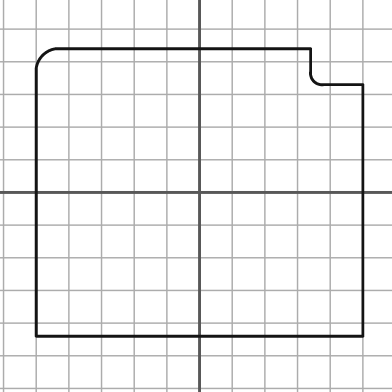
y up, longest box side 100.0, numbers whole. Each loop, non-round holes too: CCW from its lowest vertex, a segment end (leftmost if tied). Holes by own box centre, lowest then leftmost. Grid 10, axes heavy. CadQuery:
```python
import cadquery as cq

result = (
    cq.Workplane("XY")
    .moveTo(-50.0, -44.0)
    .lineTo(50.0, -44.0)
    .lineTo(50.0, 33.0)
    .lineTo(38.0, 33.0)
    .threePointArc((35.0, 34.0), (34.0, 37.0))
    .lineTo(34.0, 44.0)
    .lineTo(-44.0, 44.0)
    .threePointArc((-48.0, 42.0), (-50.0, 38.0))
    .close()
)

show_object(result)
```